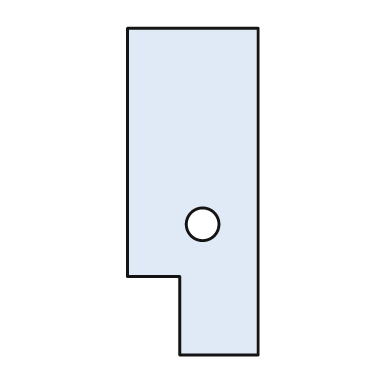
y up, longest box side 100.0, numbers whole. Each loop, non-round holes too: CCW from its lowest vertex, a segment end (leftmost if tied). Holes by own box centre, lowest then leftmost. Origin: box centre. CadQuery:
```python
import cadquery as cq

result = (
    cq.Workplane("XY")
    .moveTo(-4.0, -50.0)
    .lineTo(20.0, -50.0)
    .lineTo(20.0, 50.0)
    .lineTo(-20.0, 50.0)
    .lineTo(-20.0, -26.0)
    .lineTo(-4.0, -26.0)
    .close()
    .moveTo(3.0, -10.0)
    .circle(5.0)
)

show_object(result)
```